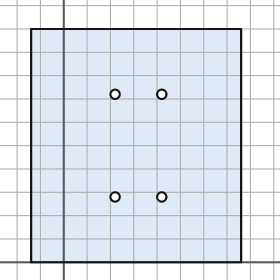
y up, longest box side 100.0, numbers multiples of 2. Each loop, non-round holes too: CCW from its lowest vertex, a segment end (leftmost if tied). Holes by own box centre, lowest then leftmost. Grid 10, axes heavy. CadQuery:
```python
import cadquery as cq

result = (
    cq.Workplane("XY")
    .moveTo(-14.0, 0.0)
    .lineTo(76.0, 0.0)
    .lineTo(76.0, 100.0)
    .lineTo(-14.0, 100.0)
    .close()
    .moveTo(22.0, 28.0)
    .circle(2.0)
    .moveTo(42.0, 28.0)
    .circle(2.0)
    .moveTo(22.0, 72.0)
    .circle(2.0)
    .moveTo(42.0, 72.0)
    .circle(2.0)
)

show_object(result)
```